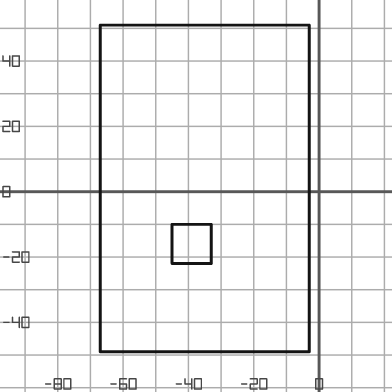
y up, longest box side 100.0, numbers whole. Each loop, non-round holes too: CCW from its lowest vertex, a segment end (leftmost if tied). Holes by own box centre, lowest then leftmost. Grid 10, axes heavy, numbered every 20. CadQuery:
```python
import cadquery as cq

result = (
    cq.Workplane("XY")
    .moveTo(-67.0, -49.0)
    .lineTo(-3.0, -49.0)
    .lineTo(-3.0, 51.0)
    .lineTo(-67.0, 51.0)
    .close()
    .moveTo(-45.0, -22.0)
    .lineTo(-33.0, -22.0)
    .lineTo(-33.0, -10.0)
    .lineTo(-45.0, -10.0)
    .close()
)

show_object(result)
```